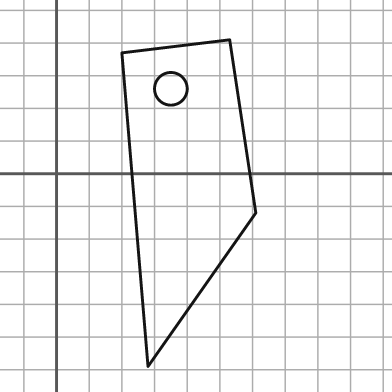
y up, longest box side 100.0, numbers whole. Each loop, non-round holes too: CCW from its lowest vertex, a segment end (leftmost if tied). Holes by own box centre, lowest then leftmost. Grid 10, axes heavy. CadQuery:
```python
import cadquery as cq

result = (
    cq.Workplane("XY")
    .moveTo(28.0, -59.0)
    .lineTo(61.0, -12.0)
    .lineTo(53.0, 41.0)
    .lineTo(20.0, 37.0)
    .close()
    .moveTo(35.0, 26.0)
    .circle(5.0)
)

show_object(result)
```